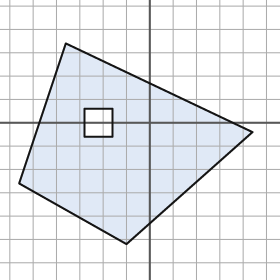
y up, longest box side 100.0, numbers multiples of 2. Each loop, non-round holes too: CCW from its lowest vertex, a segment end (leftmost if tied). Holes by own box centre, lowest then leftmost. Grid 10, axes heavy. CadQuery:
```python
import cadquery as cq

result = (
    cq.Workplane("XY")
    .moveTo(-10.0, -52.0)
    .lineTo(44.0, -4.0)
    .lineTo(-36.0, 34.0)
    .lineTo(-56.0, -26.0)
    .close()
    .moveTo(-28.0, -6.0)
    .lineTo(-16.0, -6.0)
    .lineTo(-16.0, 6.0)
    .lineTo(-28.0, 6.0)
    .close()
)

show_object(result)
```